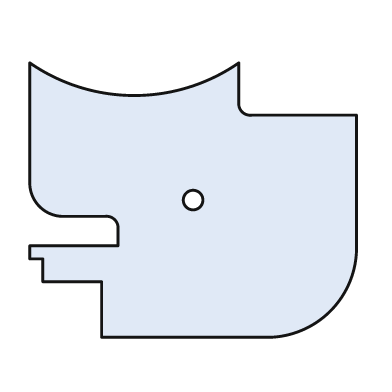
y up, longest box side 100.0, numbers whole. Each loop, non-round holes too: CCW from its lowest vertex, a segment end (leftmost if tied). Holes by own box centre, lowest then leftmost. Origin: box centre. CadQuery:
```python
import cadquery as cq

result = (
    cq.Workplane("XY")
    .moveTo(-28.0, -42.0)
    .lineTo(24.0, -42.0)
    .threePointArc((42.0, -34.0), (50.0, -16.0))
    .lineTo(50.0, 26.0)
    .lineTo(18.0, 26.0)
    .threePointArc((15.0, 27.0), (14.0, 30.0))
    .lineTo(14.0, 42.0)
    .threePointArc((-18.0, 32.0), (-50.0, 42.0))
    .lineTo(-50.0, 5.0)
    .threePointArc((-47.0, -2.0), (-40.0, -5.0))
    .lineTo(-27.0, -5.0)
    .threePointArc((-24.0, -6.0), (-23.0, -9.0))
    .lineTo(-23.0, -14.0)
    .lineTo(-50.0, -14.0)
    .lineTo(-50.0, -18.0)
    .lineTo(-46.0, -18.0)
    .lineTo(-46.0, -25.0)
    .lineTo(-28.0, -25.0)
    .close()
    .moveTo(0.0, 0.0)
    .circle(3.0)
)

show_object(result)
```